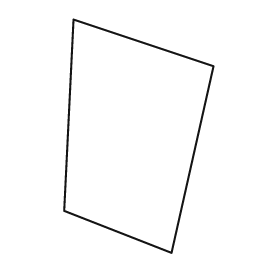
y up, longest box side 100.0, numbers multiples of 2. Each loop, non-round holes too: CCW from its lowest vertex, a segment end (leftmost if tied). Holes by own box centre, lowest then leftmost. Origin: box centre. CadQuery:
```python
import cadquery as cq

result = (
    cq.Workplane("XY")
    .moveTo(14.0, -50.0)
    .lineTo(32.0, 30.0)
    .lineTo(-28.0, 50.0)
    .lineTo(-32.0, -32.0)
    .close()
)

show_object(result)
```